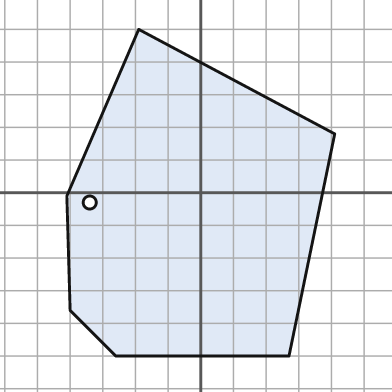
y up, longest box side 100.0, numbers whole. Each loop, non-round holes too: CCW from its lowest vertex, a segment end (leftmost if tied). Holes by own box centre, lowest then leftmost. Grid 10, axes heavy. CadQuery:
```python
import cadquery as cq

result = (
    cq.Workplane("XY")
    .moveTo(-26.0, -50.0)
    .lineTo(27.0, -50.0)
    .lineTo(41.0, 18.0)
    .lineTo(-19.0, 50.0)
    .lineTo(-41.0, -1.0)
    .lineTo(-40.0, -36.0)
    .close()
    .moveTo(-34.0, -3.0)
    .circle(2.0)
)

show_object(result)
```